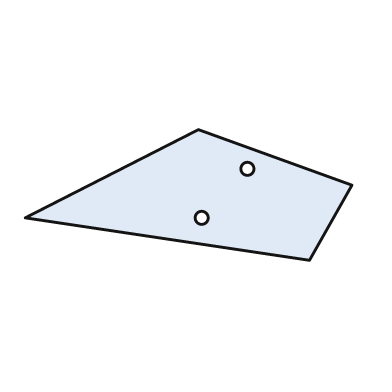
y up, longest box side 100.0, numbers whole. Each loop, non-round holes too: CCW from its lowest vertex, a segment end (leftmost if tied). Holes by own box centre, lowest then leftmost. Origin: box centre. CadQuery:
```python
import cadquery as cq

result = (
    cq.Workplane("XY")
    .moveTo(37.0, -20.0)
    .lineTo(50.0, 3.0)
    .lineTo(3.0, 20.0)
    .lineTo(-50.0, -7.0)
    .close()
    .moveTo(4.0, -7.0)
    .circle(2.0)
    .moveTo(18.0, 8.0)
    .circle(2.0)
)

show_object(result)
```